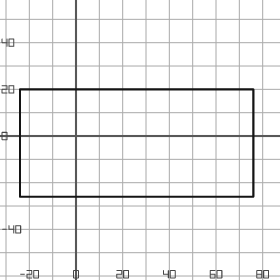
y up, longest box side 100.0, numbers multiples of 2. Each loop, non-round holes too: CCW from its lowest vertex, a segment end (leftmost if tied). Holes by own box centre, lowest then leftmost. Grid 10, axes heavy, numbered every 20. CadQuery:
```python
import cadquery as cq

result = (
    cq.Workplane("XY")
    .moveTo(-24.0, -26.0)
    .lineTo(76.0, -26.0)
    .lineTo(76.0, 20.0)
    .lineTo(-24.0, 20.0)
    .close()
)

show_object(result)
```